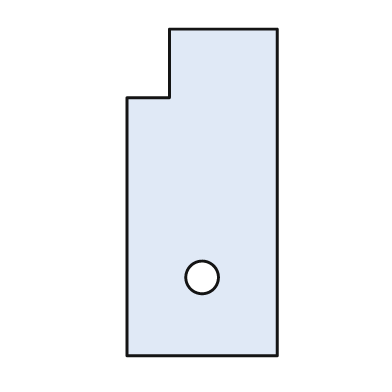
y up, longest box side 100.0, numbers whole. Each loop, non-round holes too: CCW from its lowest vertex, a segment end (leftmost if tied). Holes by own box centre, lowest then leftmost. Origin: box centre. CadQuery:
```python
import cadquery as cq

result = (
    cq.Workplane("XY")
    .moveTo(-23.0, -50.0)
    .lineTo(23.0, -50.0)
    .lineTo(23.0, 50.0)
    .lineTo(-10.0, 50.0)
    .lineTo(-10.0, 29.0)
    .lineTo(-23.0, 29.0)
    .close()
    .moveTo(0.0, -26.0)
    .circle(5.0)
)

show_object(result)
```